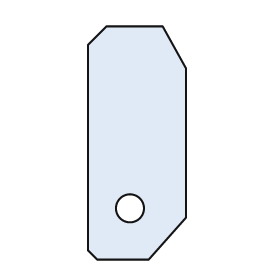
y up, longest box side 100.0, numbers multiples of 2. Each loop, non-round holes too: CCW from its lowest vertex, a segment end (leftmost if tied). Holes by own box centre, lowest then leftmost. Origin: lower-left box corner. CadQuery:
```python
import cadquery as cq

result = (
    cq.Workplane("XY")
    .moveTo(4.0, 0.0)
    .lineTo(26.0, 0.0)
    .lineTo(42.0, 18.0)
    .lineTo(42.0, 82.0)
    .lineTo(32.0, 100.0)
    .lineTo(8.0, 100.0)
    .lineTo(0.0, 92.0)
    .lineTo(0.0, 4.0)
    .close()
    .moveTo(18.0, 22.0)
    .circle(6.0)
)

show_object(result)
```